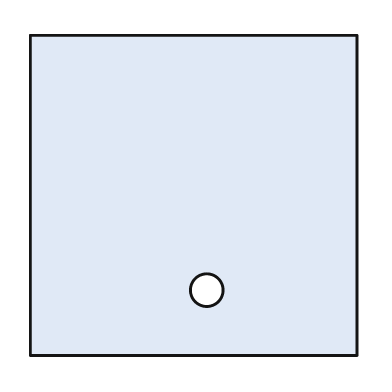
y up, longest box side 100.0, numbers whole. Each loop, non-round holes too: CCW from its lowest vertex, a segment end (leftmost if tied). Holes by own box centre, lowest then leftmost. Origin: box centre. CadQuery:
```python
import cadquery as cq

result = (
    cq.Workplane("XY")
    .moveTo(-50.0, -49.0)
    .lineTo(50.0, -49.0)
    .lineTo(50.0, 49.0)
    .lineTo(-50.0, 49.0)
    .close()
    .moveTo(4.0, -29.0)
    .circle(5.0)
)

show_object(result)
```